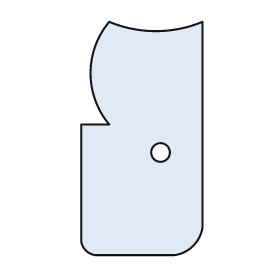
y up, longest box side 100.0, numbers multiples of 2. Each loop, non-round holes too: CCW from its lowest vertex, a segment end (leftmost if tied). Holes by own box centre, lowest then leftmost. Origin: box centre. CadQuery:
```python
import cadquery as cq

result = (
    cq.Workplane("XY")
    .moveTo(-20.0, -50.0)
    .lineTo(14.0, -50.0)
    .threePointArc((22.0, -46.0), (26.0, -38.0))
    .lineTo(26.0, 50.0)
    .threePointArc((6.0, 46.0), (-14.0, 50.0))
    .threePointArc((-22.0, 28.0), (-14.0, 6.0))
    .lineTo(-26.0, 6.0)
    .lineTo(-26.0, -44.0)
    .threePointArc((-24.0, -48.0), (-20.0, -50.0))
    .close()
    .moveTo(8.0, -6.0)
    .circle(4.0)
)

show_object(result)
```